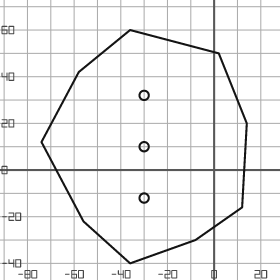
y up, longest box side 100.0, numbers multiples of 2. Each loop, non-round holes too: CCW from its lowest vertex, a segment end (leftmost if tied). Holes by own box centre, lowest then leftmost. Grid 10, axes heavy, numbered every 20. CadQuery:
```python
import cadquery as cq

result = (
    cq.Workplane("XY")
    .moveTo(-36.0, -40.0)
    .lineTo(-8.0, -30.0)
    .lineTo(12.0, -16.0)
    .lineTo(14.0, 20.0)
    .lineTo(2.0, 50.0)
    .lineTo(-36.0, 60.0)
    .lineTo(-58.0, 42.0)
    .lineTo(-74.0, 12.0)
    .lineTo(-56.0, -22.0)
    .close()
    .moveTo(-30.0, -12.0)
    .circle(2.0)
    .moveTo(-30.0, 10.0)
    .circle(2.0)
    .moveTo(-30.0, 32.0)
    .circle(2.0)
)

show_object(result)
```